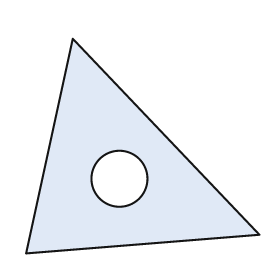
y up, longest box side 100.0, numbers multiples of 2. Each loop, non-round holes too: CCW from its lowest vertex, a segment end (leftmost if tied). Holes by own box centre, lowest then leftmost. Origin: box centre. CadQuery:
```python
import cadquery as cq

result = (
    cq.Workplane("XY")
    .moveTo(-50.0, -46.0)
    .lineTo(50.0, -38.0)
    .lineTo(-30.0, 46.0)
    .close()
    .moveTo(-10.0, -14.0)
    .circle(12.0)
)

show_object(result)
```